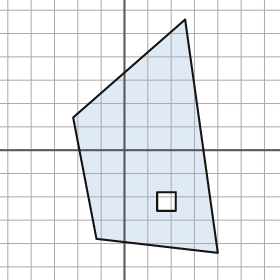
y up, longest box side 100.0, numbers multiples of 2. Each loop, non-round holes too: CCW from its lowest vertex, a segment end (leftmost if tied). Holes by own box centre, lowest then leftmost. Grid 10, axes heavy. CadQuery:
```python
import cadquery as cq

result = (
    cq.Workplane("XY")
    .moveTo(40.0, -44.0)
    .lineTo(26.0, 56.0)
    .lineTo(-22.0, 14.0)
    .lineTo(-12.0, -38.0)
    .close()
    .moveTo(14.0, -26.0)
    .lineTo(22.0, -26.0)
    .lineTo(22.0, -18.0)
    .lineTo(14.0, -18.0)
    .close()
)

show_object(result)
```